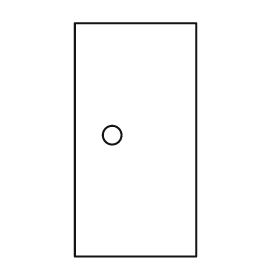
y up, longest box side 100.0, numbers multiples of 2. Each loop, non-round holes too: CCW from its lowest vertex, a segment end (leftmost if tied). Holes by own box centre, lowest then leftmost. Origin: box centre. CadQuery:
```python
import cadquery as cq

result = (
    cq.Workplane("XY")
    .moveTo(-26.0, -50.0)
    .lineTo(26.0, -50.0)
    .lineTo(26.0, 50.0)
    .lineTo(-26.0, 50.0)
    .close()
    .moveTo(-10.0, 2.0)
    .circle(4.0)
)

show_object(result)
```